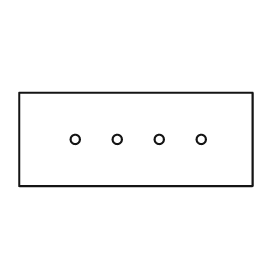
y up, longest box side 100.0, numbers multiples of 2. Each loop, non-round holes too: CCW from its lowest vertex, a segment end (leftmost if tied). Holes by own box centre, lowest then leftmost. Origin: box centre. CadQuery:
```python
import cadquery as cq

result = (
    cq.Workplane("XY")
    .moveTo(-50.0, -20.0)
    .lineTo(50.0, -20.0)
    .lineTo(50.0, 20.0)
    .lineTo(-50.0, 20.0)
    .close()
    .moveTo(-26.0, 0.0)
    .circle(2.0)
    .moveTo(-8.0, 0.0)
    .circle(2.0)
    .moveTo(10.0, 0.0)
    .circle(2.0)
    .moveTo(28.0, 0.0)
    .circle(2.0)
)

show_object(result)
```